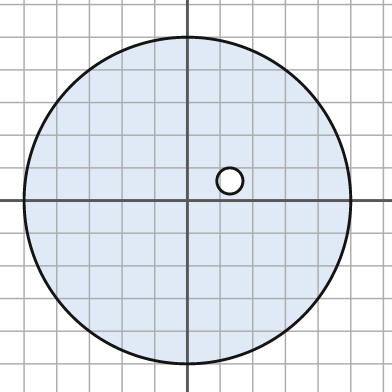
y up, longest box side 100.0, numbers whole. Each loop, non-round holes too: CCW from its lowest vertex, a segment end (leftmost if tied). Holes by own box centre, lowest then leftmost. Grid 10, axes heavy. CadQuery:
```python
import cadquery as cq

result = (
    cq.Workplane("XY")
    .moveTo(0.0, 0.0)
    .circle(50.0)
    .moveTo(13.0, 6.0)
    .circle(4.0)
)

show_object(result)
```